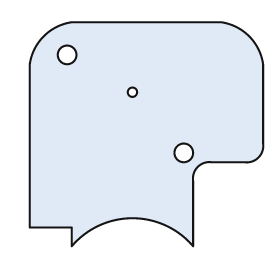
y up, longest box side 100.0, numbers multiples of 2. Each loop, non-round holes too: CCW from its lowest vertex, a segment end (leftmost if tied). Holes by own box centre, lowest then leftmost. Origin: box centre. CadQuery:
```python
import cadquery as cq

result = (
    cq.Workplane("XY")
    .moveTo(-32.0, -48.0)
    .threePointArc((-6.0, -36.0), (20.0, -48.0))
    .lineTo(20.0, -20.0)
    .threePointArc((22.0, -14.0), (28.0, -12.0))
    .lineTo(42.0, -12.0)
    .threePointArc((48.0, -10.0), (50.0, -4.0))
    .lineTo(50.0, 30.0)
    .threePointArc((44.0, 42.0), (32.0, 48.0))
    .lineTo(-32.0, 48.0)
    .threePointArc((-44.0, 42.0), (-50.0, 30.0))
    .lineTo(-50.0, -40.0)
    .lineTo(-32.0, -40.0)
    .close()
    .moveTo(16.0, -8.0)
    .circle(4.0)
    .moveTo(-6.0, 18.0)
    .circle(2.0)
    .moveTo(-34.0, 34.0)
    .circle(4.0)
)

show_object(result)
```